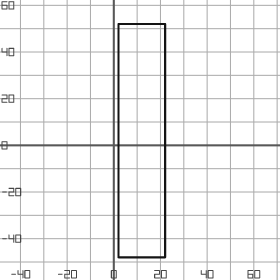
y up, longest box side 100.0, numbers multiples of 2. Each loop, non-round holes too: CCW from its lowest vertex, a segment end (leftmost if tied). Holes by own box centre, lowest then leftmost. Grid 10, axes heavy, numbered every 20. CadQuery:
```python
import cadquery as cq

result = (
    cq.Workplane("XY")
    .moveTo(2.0, -48.0)
    .lineTo(22.0, -48.0)
    .lineTo(22.0, 52.0)
    .lineTo(2.0, 52.0)
    .close()
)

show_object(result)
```